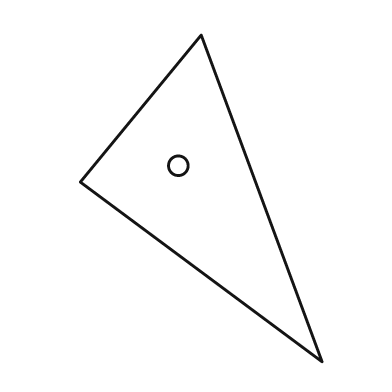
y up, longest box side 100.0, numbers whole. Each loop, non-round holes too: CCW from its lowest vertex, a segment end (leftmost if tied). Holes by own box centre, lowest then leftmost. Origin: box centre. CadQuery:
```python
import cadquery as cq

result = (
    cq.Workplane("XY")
    .moveTo(37.0, -50.0)
    .lineTo(0.0, 50.0)
    .lineTo(-37.0, 5.0)
    .close()
    .moveTo(-7.0, 10.0)
    .circle(3.0)
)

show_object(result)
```